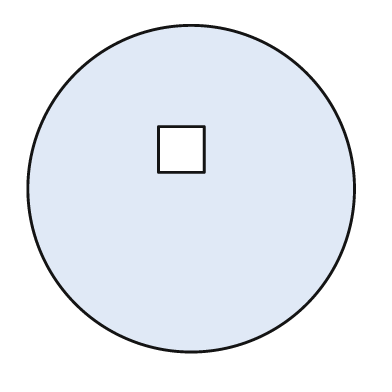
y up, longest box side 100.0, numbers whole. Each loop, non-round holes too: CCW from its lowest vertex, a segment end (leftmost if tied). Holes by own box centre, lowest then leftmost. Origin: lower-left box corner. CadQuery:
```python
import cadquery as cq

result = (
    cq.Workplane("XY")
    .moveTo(50.0, 50.0)
    .circle(50.0)
    .moveTo(40.0, 55.0)
    .lineTo(54.0, 55.0)
    .lineTo(54.0, 69.0)
    .lineTo(40.0, 69.0)
    .close()
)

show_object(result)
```